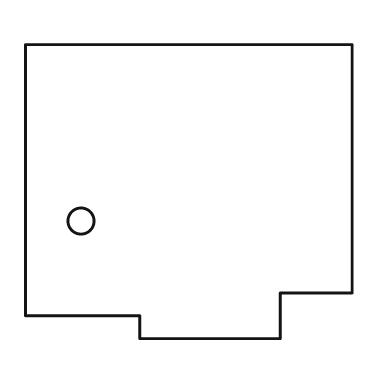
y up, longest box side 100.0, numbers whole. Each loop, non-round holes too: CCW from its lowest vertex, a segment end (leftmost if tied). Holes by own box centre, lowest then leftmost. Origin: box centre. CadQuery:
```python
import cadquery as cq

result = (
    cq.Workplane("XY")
    .moveTo(-15.0, -45.0)
    .lineTo(28.0, -45.0)
    .lineTo(28.0, -31.0)
    .lineTo(50.0, -31.0)
    .lineTo(50.0, 45.0)
    .lineTo(-50.0, 45.0)
    .lineTo(-50.0, -38.0)
    .lineTo(-15.0, -38.0)
    .close()
    .moveTo(-33.0, -9.0)
    .circle(4.0)
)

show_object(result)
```